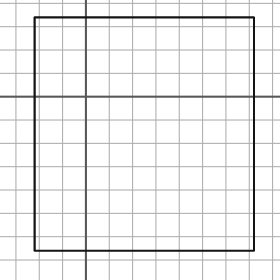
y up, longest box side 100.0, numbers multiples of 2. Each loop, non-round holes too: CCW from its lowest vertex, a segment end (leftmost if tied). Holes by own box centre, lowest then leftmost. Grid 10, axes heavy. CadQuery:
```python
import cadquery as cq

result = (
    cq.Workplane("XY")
    .moveTo(-22.0, -66.0)
    .lineTo(72.0, -66.0)
    .lineTo(72.0, 34.0)
    .lineTo(-22.0, 34.0)
    .close()
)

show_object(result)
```